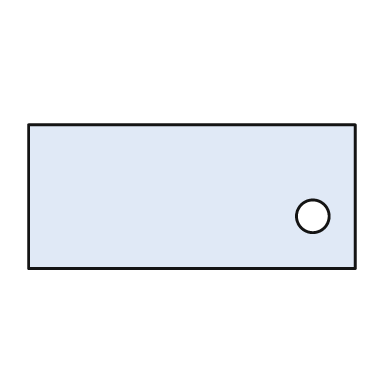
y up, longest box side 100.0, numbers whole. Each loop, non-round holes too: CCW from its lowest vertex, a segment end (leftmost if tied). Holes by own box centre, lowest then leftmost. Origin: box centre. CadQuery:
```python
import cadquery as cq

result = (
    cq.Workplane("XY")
    .moveTo(-50.0, -22.0)
    .lineTo(50.0, -22.0)
    .lineTo(50.0, 22.0)
    .lineTo(-50.0, 22.0)
    .close()
    .moveTo(37.0, -6.0)
    .circle(5.0)
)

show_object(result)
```